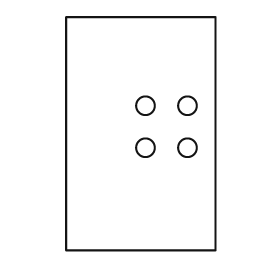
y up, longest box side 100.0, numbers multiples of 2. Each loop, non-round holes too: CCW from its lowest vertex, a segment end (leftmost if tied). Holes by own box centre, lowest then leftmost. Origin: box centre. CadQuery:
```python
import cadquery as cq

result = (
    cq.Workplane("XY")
    .moveTo(-32.0, -50.0)
    .lineTo(32.0, -50.0)
    .lineTo(32.0, 50.0)
    .lineTo(-32.0, 50.0)
    .close()
    .moveTo(2.0, -6.0)
    .circle(4.0)
    .moveTo(20.0, -6.0)
    .circle(4.0)
    .moveTo(2.0, 12.0)
    .circle(4.0)
    .moveTo(20.0, 12.0)
    .circle(4.0)
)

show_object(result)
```